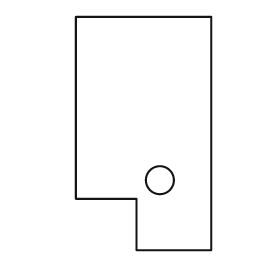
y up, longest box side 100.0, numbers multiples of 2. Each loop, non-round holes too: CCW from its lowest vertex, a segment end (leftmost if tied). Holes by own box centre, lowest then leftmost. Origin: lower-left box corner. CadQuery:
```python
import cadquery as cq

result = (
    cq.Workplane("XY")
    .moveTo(26.0, 0.0)
    .lineTo(58.0, 0.0)
    .lineTo(58.0, 100.0)
    .lineTo(0.0, 100.0)
    .lineTo(0.0, 22.0)
    .lineTo(26.0, 22.0)
    .close()
    .moveTo(36.0, 30.0)
    .circle(6.0)
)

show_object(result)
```